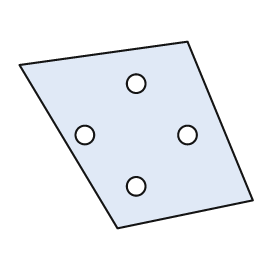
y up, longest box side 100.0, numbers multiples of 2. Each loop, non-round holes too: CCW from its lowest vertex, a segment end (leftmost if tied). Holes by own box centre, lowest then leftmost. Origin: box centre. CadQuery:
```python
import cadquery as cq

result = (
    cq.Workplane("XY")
    .moveTo(-8.0, -40.0)
    .lineTo(50.0, -28.0)
    .lineTo(22.0, 40.0)
    .lineTo(-50.0, 30.0)
    .close()
    .moveTo(0.0, -22.0)
    .circle(4.0)
    .moveTo(-22.0, 0.0)
    .circle(4.0)
    .moveTo(22.0, 0.0)
    .circle(4.0)
    .moveTo(0.0, 22.0)
    .circle(4.0)
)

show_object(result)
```